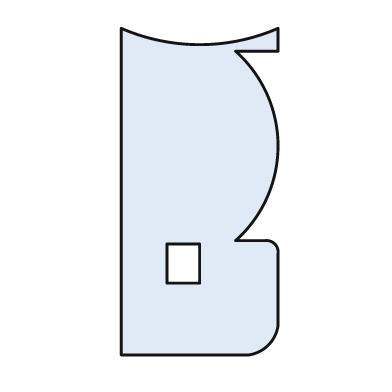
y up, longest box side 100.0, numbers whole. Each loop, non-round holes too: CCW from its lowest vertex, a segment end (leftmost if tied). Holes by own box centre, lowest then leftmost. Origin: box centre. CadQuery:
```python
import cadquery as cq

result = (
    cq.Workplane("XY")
    .moveTo(-24.0, -50.0)
    .lineTo(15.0, -50.0)
    .threePointArc((21.0, -47.0), (24.0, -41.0))
    .lineTo(24.0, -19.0)
    .threePointArc((23.0, -16.0), (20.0, -15.0))
    .lineTo(11.0, -15.0)
    .threePointArc((24.0, 14.0), (11.0, 43.0))
    .lineTo(24.0, 43.0)
    .lineTo(24.0, 50.0)
    .threePointArc((0.0, 45.0), (-24.0, 50.0))
    .close()
    .moveTo(-10.0, -28.0)
    .lineTo(0.0, -28.0)
    .lineTo(0.0, -16.0)
    .lineTo(-10.0, -16.0)
    .close()
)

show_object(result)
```